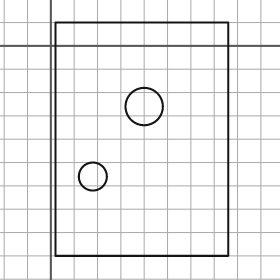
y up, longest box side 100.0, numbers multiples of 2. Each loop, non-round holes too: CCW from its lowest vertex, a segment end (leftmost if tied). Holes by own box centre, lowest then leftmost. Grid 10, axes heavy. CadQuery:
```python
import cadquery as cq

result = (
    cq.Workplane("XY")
    .moveTo(2.0, -90.0)
    .lineTo(76.0, -90.0)
    .lineTo(76.0, 10.0)
    .lineTo(2.0, 10.0)
    .close()
    .moveTo(18.0, -56.0)
    .circle(6.0)
    .moveTo(40.0, -26.0)
    .circle(8.0)
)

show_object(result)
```